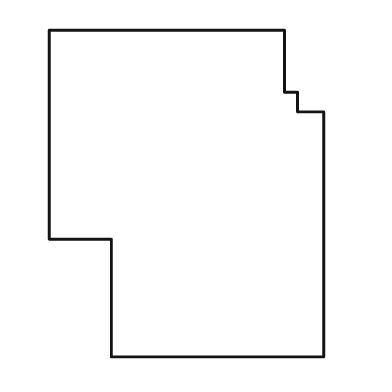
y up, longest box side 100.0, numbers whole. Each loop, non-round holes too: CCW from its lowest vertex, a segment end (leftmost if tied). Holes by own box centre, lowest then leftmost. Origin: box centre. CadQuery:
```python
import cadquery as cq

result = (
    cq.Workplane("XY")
    .moveTo(-23.0, -50.0)
    .lineTo(42.0, -50.0)
    .lineTo(42.0, 25.0)
    .lineTo(34.0, 25.0)
    .lineTo(34.0, 31.0)
    .lineTo(30.0, 31.0)
    .lineTo(30.0, 50.0)
    .lineTo(-42.0, 50.0)
    .lineTo(-42.0, -14.0)
    .lineTo(-23.0, -14.0)
    .close()
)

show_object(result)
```